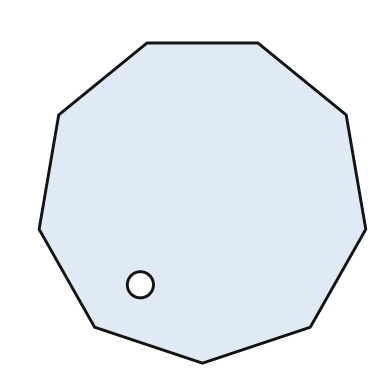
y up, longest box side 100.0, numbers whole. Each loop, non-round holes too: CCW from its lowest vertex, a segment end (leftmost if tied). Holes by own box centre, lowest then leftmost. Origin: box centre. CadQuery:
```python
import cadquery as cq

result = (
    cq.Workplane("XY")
    .moveTo(0.0, -49.0)
    .lineTo(33.0, -38.0)
    .lineTo(50.0, -8.0)
    .lineTo(44.0, 27.0)
    .lineTo(17.0, 49.0)
    .lineTo(-17.0, 49.0)
    .lineTo(-44.0, 27.0)
    .lineTo(-50.0, -8.0)
    .lineTo(-33.0, -38.0)
    .close()
    .moveTo(-19.0, -25.0)
    .circle(4.0)
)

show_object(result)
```